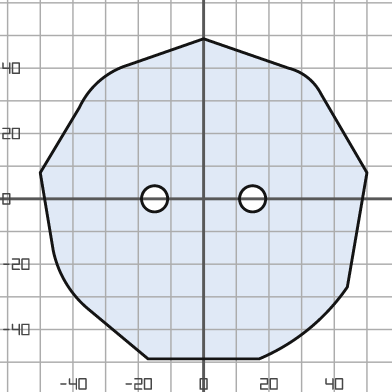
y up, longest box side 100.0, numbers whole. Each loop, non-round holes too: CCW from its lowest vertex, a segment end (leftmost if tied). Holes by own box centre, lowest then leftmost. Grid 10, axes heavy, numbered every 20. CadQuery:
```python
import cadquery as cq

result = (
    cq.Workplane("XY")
    .moveTo(-17.0, -49.0)
    .lineTo(17.0, -49.0)
    .threePointArc((32.0, -40.0), (44.0, -27.0))
    .lineTo(50.0, 8.0)
    .lineTo(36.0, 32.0)
    .threePointArc((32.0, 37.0), (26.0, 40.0))
    .lineTo(0.0, 49.0)
    .lineTo(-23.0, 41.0)
    .threePointArc((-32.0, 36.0), (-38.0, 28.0))
    .lineTo(-50.0, 8.0)
    .lineTo(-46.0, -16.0)
    .threePointArc((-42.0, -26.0), (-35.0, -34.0))
    .close()
    .moveTo(-15.0, 0.0)
    .circle(4.0)
    .moveTo(15.0, 0.0)
    .circle(4.0)
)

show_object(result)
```